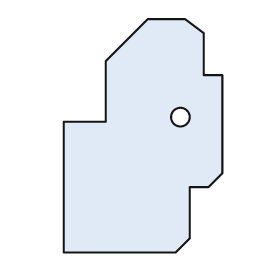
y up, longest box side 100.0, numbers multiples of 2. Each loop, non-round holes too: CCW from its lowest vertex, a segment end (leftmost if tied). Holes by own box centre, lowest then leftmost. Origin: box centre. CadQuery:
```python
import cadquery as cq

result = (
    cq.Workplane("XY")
    .moveTo(-34.0, -50.0)
    .lineTo(14.0, -50.0)
    .lineTo(20.0, -44.0)
    .lineTo(20.0, -22.0)
    .lineTo(28.0, -22.0)
    .lineTo(34.0, -16.0)
    .lineTo(34.0, 26.0)
    .lineTo(26.0, 26.0)
    .lineTo(26.0, 44.0)
    .lineTo(18.0, 50.0)
    .lineTo(2.0, 50.0)
    .lineTo(-16.0, 32.0)
    .lineTo(-16.0, 6.0)
    .lineTo(-34.0, 6.0)
    .close()
    .moveTo(16.0, 8.0)
    .circle(4.0)
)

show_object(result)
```